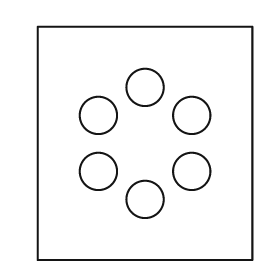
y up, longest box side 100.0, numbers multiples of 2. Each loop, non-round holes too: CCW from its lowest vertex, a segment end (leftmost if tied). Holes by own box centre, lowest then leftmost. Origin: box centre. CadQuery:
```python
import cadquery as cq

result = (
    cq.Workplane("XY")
    .moveTo(-46.0, -50.0)
    .lineTo(46.0, -50.0)
    .lineTo(46.0, 50.0)
    .lineTo(-46.0, 50.0)
    .close()
    .moveTo(0.0, -24.0)
    .circle(8.0)
    .moveTo(-20.0, -12.0)
    .circle(8.0)
    .moveTo(20.0, -12.0)
    .circle(8.0)
    .moveTo(-20.0, 12.0)
    .circle(8.0)
    .moveTo(20.0, 12.0)
    .circle(8.0)
    .moveTo(0.0, 24.0)
    .circle(8.0)
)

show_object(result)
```